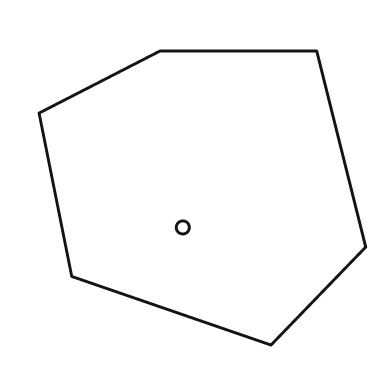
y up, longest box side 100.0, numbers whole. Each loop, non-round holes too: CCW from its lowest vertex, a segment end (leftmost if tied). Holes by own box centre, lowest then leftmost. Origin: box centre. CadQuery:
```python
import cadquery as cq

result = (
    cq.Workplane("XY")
    .moveTo(21.0, -45.0)
    .lineTo(50.0, -15.0)
    .lineTo(35.0, 45.0)
    .lineTo(-13.0, 45.0)
    .lineTo(-50.0, 26.0)
    .lineTo(-40.0, -24.0)
    .close()
    .moveTo(-6.0, -9.0)
    .circle(2.0)
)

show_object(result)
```